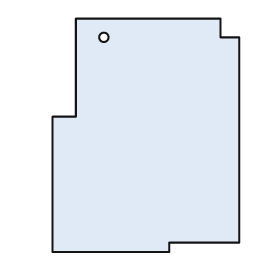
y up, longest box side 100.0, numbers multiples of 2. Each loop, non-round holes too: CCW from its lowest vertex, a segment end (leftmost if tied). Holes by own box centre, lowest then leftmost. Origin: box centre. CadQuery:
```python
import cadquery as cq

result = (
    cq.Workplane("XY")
    .moveTo(-40.0, -50.0)
    .lineTo(10.0, -50.0)
    .lineTo(10.0, -46.0)
    .lineTo(40.0, -46.0)
    .lineTo(40.0, 42.0)
    .lineTo(32.0, 42.0)
    .lineTo(32.0, 50.0)
    .lineTo(-30.0, 50.0)
    .lineTo(-30.0, 8.0)
    .lineTo(-40.0, 8.0)
    .close()
    .moveTo(-18.0, 42.0)
    .circle(2.0)
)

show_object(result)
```